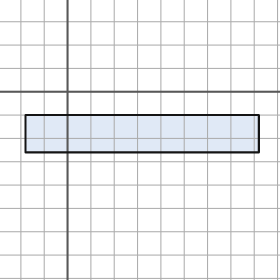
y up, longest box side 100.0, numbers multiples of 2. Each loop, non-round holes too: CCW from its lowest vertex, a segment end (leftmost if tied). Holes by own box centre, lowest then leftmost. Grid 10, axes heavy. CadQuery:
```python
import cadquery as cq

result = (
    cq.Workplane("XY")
    .moveTo(-18.0, -26.0)
    .lineTo(82.0, -26.0)
    .lineTo(82.0, -10.0)
    .lineTo(-18.0, -10.0)
    .close()
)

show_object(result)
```